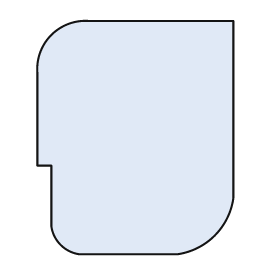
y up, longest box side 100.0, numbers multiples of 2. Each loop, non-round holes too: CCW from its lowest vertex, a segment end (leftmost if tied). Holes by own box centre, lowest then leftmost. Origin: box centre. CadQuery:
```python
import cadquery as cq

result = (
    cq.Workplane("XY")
    .moveTo(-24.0, -50.0)
    .lineTo(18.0, -50.0)
    .threePointArc((34.0, -42.0), (42.0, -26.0))
    .lineTo(42.0, 50.0)
    .lineTo(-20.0, 50.0)
    .threePointArc((-36.0, 44.0), (-42.0, 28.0))
    .lineTo(-42.0, -12.0)
    .lineTo(-36.0, -12.0)
    .lineTo(-36.0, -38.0)
    .threePointArc((-32.0, -46.0), (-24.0, -50.0))
    .close()
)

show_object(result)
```